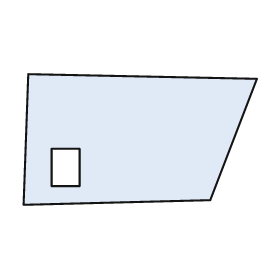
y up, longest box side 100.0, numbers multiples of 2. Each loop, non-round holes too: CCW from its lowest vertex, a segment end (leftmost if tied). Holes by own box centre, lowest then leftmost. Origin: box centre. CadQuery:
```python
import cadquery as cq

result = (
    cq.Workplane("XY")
    .moveTo(-50.0, -28.0)
    .lineTo(30.0, -26.0)
    .lineTo(50.0, 26.0)
    .lineTo(-48.0, 28.0)
    .close()
    .moveTo(-38.0, -20.0)
    .lineTo(-26.0, -20.0)
    .lineTo(-26.0, -4.0)
    .lineTo(-38.0, -4.0)
    .close()
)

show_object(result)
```